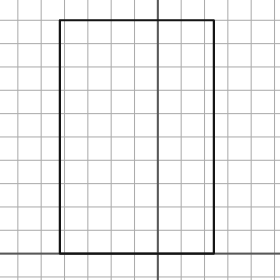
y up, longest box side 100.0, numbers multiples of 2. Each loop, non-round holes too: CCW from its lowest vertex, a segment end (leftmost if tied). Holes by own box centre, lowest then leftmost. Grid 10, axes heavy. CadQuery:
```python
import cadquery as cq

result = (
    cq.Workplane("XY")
    .moveTo(-42.0, 0.0)
    .lineTo(24.0, 0.0)
    .lineTo(24.0, 100.0)
    .lineTo(-42.0, 100.0)
    .close()
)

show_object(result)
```